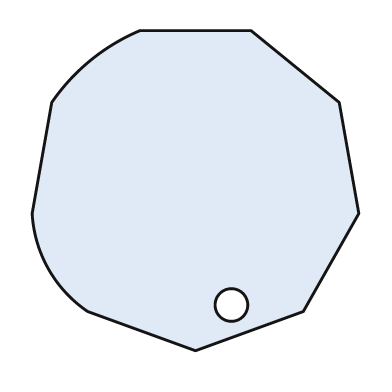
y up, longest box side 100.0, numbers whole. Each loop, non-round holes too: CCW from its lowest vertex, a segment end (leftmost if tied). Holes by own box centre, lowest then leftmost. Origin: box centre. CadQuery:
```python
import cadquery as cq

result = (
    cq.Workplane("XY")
    .moveTo(0.0, -49.0)
    .lineTo(33.0, -37.0)
    .lineTo(50.0, -7.0)
    .lineTo(44.0, 27.0)
    .lineTo(17.0, 49.0)
    .lineTo(-17.0, 49.0)
    .threePointArc((-32.0, 40.0), (-44.0, 27.0))
    .lineTo(-50.0, -7.0)
    .threePointArc((-45.0, -24.0), (-33.0, -37.0))
    .close()
    .moveTo(11.0, -35.0)
    .circle(5.0)
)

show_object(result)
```